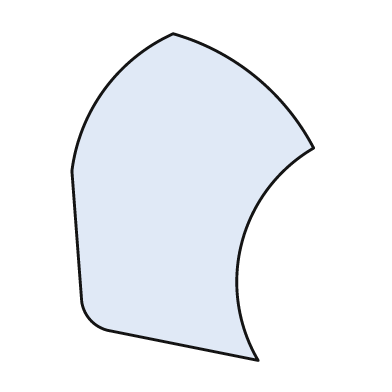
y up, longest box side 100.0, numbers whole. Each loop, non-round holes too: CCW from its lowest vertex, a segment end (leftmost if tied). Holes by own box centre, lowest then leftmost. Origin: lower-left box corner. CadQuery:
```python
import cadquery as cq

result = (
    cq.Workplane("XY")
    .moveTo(57.0, 0.0)
    .threePointArc((52.0, 36.0), (74.0, 65.0))
    .threePointArc((56.0, 87.0), (31.0, 100.0))
    .threePointArc((10.0, 83.0), (0.0, 58.0))
    .lineTo(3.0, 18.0)
    .threePointArc((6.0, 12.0), (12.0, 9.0))
    .close()
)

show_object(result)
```